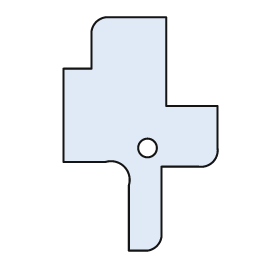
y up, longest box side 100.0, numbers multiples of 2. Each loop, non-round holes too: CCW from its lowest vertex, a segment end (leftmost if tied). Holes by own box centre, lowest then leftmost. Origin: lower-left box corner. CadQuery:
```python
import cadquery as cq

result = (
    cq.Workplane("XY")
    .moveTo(28.0, 0.0)
    .lineTo(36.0, 0.0)
    .threePointArc((40.0, 2.0), (42.0, 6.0))
    .lineTo(42.0, 36.0)
    .lineTo(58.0, 36.0)
    .threePointArc((64.0, 38.0), (66.0, 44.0))
    .lineTo(66.0, 62.0)
    .lineTo(44.0, 62.0)
    .lineTo(44.0, 100.0)
    .lineTo(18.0, 100.0)
    .threePointArc((14.0, 98.0), (12.0, 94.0))
    .lineTo(12.0, 78.0)
    .lineTo(0.0, 78.0)
    .lineTo(0.0, 38.0)
    .lineTo(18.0, 38.0)
    .threePointArc((26.0, 36.0), (28.0, 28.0))
    .close()
    .moveTo(36.0, 44.0)
    .circle(4.0)
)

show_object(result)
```